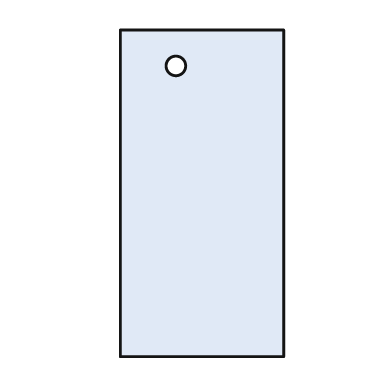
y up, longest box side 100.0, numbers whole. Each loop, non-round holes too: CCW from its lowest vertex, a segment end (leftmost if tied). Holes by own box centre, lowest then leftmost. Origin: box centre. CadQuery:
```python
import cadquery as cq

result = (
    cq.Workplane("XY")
    .moveTo(-25.0, -50.0)
    .lineTo(25.0, -50.0)
    .lineTo(25.0, 50.0)
    .lineTo(-25.0, 50.0)
    .close()
    .moveTo(-8.0, 39.0)
    .circle(3.0)
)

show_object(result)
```